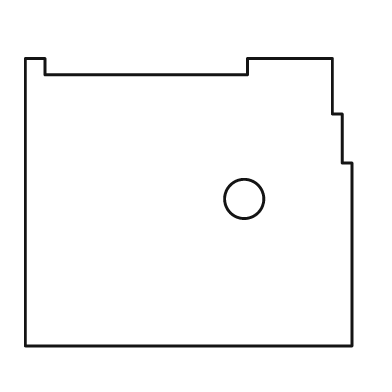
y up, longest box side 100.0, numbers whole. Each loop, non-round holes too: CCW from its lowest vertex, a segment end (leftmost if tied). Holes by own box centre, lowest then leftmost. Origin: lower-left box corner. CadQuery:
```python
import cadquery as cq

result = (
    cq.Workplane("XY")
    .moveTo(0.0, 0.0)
    .lineTo(100.0, 0.0)
    .lineTo(100.0, 56.0)
    .lineTo(97.0, 56.0)
    .lineTo(97.0, 71.0)
    .lineTo(94.0, 71.0)
    .lineTo(94.0, 88.0)
    .lineTo(68.0, 88.0)
    .lineTo(68.0, 83.0)
    .lineTo(6.0, 83.0)
    .lineTo(6.0, 88.0)
    .lineTo(0.0, 88.0)
    .close()
    .moveTo(67.0, 45.0)
    .circle(6.0)
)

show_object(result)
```